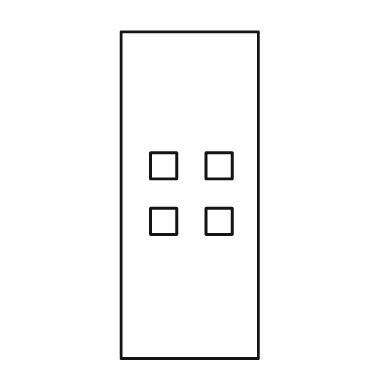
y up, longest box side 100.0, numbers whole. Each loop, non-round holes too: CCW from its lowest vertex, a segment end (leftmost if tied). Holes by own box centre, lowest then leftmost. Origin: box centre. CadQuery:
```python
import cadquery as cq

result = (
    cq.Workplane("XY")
    .moveTo(-21.0, -50.0)
    .lineTo(21.0, -50.0)
    .lineTo(21.0, 50.0)
    .lineTo(-21.0, 50.0)
    .close()
    .moveTo(-12.0, -12.0)
    .lineTo(-4.0, -12.0)
    .lineTo(-4.0, -4.0)
    .lineTo(-12.0, -4.0)
    .close()
    .moveTo(5.0, -12.0)
    .lineTo(13.0, -12.0)
    .lineTo(13.0, -4.0)
    .lineTo(5.0, -4.0)
    .close()
    .moveTo(-12.0, 5.0)
    .lineTo(-4.0, 5.0)
    .lineTo(-4.0, 13.0)
    .lineTo(-12.0, 13.0)
    .close()
    .moveTo(5.0, 5.0)
    .lineTo(13.0, 5.0)
    .lineTo(13.0, 13.0)
    .lineTo(5.0, 13.0)
    .close()
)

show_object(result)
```